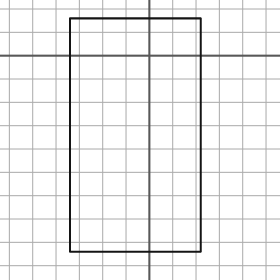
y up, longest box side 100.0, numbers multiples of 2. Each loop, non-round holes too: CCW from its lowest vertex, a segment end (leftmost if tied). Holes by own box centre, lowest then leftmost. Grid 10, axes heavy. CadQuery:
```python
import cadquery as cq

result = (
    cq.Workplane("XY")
    .moveTo(-34.0, -84.0)
    .lineTo(22.0, -84.0)
    .lineTo(22.0, 16.0)
    .lineTo(-34.0, 16.0)
    .close()
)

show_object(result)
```